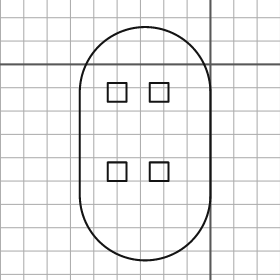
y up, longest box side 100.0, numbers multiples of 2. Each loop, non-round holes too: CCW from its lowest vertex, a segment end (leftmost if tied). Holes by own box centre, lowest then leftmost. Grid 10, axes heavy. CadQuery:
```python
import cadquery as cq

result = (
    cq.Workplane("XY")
    .moveTo(-56.0, -56.0)
    .threePointArc((-28.0, -84.0), (0.0, -56.0))
    .lineTo(0.0, -12.0)
    .threePointArc((-28.0, 16.0), (-56.0, -12.0))
    .close()
    .moveTo(-44.0, -50.0)
    .lineTo(-36.0, -50.0)
    .lineTo(-36.0, -42.0)
    .lineTo(-44.0, -42.0)
    .close()
    .moveTo(-26.0, -50.0)
    .lineTo(-18.0, -50.0)
    .lineTo(-18.0, -42.0)
    .lineTo(-26.0, -42.0)
    .close()
    .moveTo(-44.0, -16.0)
    .lineTo(-36.0, -16.0)
    .lineTo(-36.0, -8.0)
    .lineTo(-44.0, -8.0)
    .close()
    .moveTo(-26.0, -16.0)
    .lineTo(-18.0, -16.0)
    .lineTo(-18.0, -8.0)
    .lineTo(-26.0, -8.0)
    .close()
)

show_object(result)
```